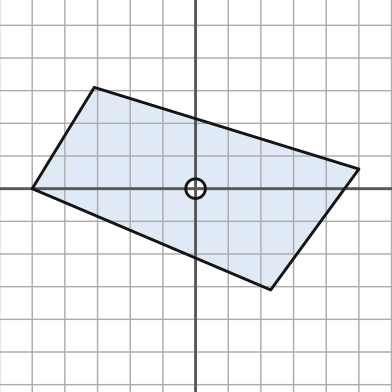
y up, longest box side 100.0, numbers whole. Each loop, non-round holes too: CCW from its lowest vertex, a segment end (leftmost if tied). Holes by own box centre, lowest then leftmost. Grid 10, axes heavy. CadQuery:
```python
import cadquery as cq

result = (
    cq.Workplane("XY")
    .moveTo(23.0, -31.0)
    .lineTo(50.0, 6.0)
    .lineTo(-31.0, 31.0)
    .lineTo(-50.0, 0.0)
    .close()
    .moveTo(0.0, 0.0)
    .circle(3.0)
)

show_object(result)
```